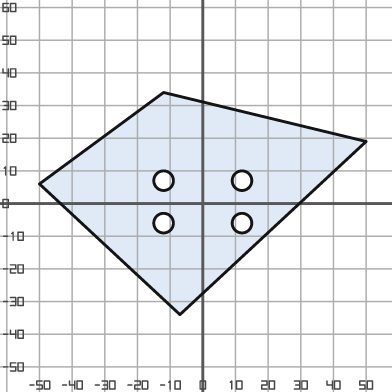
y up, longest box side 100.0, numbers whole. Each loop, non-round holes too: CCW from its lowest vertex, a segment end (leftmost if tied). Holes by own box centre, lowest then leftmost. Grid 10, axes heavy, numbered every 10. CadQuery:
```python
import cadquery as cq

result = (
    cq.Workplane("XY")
    .moveTo(-7.0, -34.0)
    .lineTo(50.0, 19.0)
    .lineTo(-12.0, 34.0)
    .lineTo(-50.0, 6.0)
    .close()
    .moveTo(-12.0, -6.0)
    .circle(3.0)
    .moveTo(12.0, -6.0)
    .circle(3.0)
    .moveTo(-12.0, 7.0)
    .circle(3.0)
    .moveTo(12.0, 7.0)
    .circle(3.0)
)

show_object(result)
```